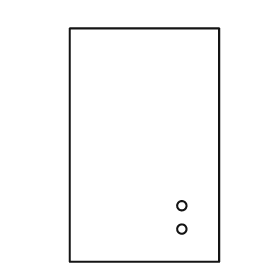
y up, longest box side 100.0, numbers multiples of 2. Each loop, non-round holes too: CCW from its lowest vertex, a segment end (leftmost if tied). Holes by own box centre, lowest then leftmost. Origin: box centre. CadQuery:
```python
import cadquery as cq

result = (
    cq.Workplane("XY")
    .moveTo(-32.0, -50.0)
    .lineTo(32.0, -50.0)
    .lineTo(32.0, 50.0)
    .lineTo(-32.0, 50.0)
    .close()
    .moveTo(16.0, -36.0)
    .circle(2.0)
    .moveTo(16.0, -26.0)
    .circle(2.0)
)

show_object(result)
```